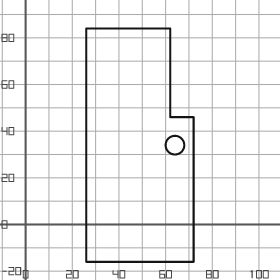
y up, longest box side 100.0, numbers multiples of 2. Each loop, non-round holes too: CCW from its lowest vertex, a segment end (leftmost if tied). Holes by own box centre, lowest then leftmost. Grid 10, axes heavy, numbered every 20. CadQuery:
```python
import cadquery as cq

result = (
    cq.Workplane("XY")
    .moveTo(26.0, -16.0)
    .lineTo(72.0, -16.0)
    .lineTo(72.0, 46.0)
    .lineTo(62.0, 46.0)
    .lineTo(62.0, 84.0)
    .lineTo(26.0, 84.0)
    .close()
    .moveTo(64.0, 34.0)
    .circle(4.0)
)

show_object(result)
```